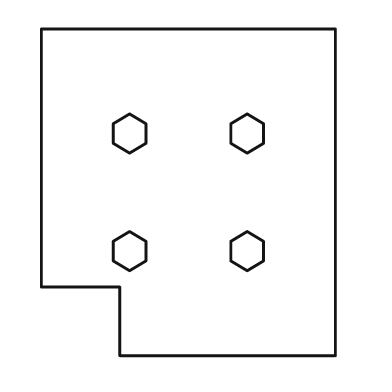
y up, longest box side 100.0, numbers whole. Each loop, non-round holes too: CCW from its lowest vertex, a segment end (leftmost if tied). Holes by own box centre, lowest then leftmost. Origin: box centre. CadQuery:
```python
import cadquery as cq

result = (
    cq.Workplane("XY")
    .moveTo(-21.0, -50.0)
    .lineTo(45.0, -50.0)
    .lineTo(45.0, 50.0)
    .lineTo(-45.0, 50.0)
    .lineTo(-45.0, -29.0)
    .lineTo(-21.0, -29.0)
    .close()
    .moveTo(-18.0, -24.0)
    .lineTo(-13.0, -21.0)
    .lineTo(-13.0, -15.0)
    .lineTo(-18.0, -12.0)
    .lineTo(-23.0, -15.0)
    .lineTo(-23.0, -21.0)
    .close()
    .moveTo(18.0, -24.0)
    .lineTo(23.0, -21.0)
    .lineTo(23.0, -15.0)
    .lineTo(18.0, -12.0)
    .lineTo(13.0, -15.0)
    .lineTo(13.0, -21.0)
    .close()
    .moveTo(-18.0, 12.0)
    .lineTo(-13.0, 15.0)
    .lineTo(-13.0, 21.0)
    .lineTo(-18.0, 24.0)
    .lineTo(-23.0, 21.0)
    .lineTo(-23.0, 15.0)
    .close()
    .moveTo(18.0, 12.0)
    .lineTo(23.0, 15.0)
    .lineTo(23.0, 21.0)
    .lineTo(18.0, 24.0)
    .lineTo(13.0, 21.0)
    .lineTo(13.0, 15.0)
    .close()
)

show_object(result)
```